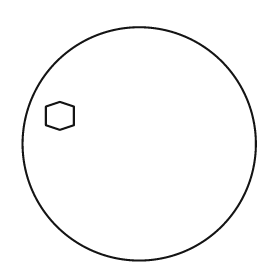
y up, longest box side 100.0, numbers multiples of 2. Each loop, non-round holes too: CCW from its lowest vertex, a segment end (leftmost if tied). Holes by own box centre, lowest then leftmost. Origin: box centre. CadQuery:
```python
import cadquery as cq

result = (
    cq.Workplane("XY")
    .moveTo(0.0, 0.0)
    .circle(50.0)
    .moveTo(-34.0, 6.0)
    .lineTo(-28.0, 8.0)
    .lineTo(-28.0, 16.0)
    .lineTo(-34.0, 18.0)
    .lineTo(-40.0, 16.0)
    .lineTo(-40.0, 8.0)
    .close()
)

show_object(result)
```